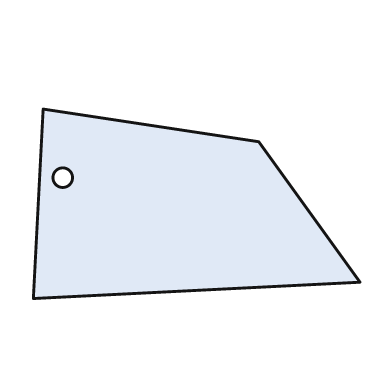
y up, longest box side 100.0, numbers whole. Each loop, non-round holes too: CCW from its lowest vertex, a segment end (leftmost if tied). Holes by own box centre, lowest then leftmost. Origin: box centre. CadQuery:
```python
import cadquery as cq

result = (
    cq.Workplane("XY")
    .moveTo(-50.0, -29.0)
    .lineTo(50.0, -24.0)
    .lineTo(19.0, 19.0)
    .lineTo(-47.0, 29.0)
    .close()
    .moveTo(-41.0, 8.0)
    .circle(3.0)
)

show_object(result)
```